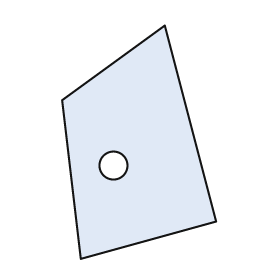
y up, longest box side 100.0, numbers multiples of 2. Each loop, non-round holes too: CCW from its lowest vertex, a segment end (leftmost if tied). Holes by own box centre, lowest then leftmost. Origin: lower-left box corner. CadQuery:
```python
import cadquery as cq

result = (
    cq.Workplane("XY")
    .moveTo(8.0, 0.0)
    .lineTo(66.0, 16.0)
    .lineTo(44.0, 100.0)
    .lineTo(0.0, 68.0)
    .close()
    .moveTo(22.0, 40.0)
    .circle(6.0)
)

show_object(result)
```